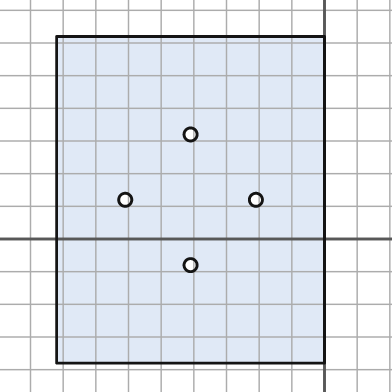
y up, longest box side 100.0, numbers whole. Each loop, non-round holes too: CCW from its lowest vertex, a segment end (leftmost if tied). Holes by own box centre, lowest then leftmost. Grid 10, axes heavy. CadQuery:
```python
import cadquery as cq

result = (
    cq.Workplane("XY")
    .moveTo(-82.0, -38.0)
    .lineTo(0.0, -38.0)
    .lineTo(0.0, 62.0)
    .lineTo(-82.0, 62.0)
    .close()
    .moveTo(-41.0, -8.0)
    .circle(2.0)
    .moveTo(-61.0, 12.0)
    .circle(2.0)
    .moveTo(-21.0, 12.0)
    .circle(2.0)
    .moveTo(-41.0, 32.0)
    .circle(2.0)
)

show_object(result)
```